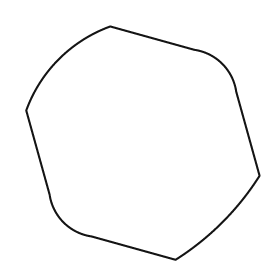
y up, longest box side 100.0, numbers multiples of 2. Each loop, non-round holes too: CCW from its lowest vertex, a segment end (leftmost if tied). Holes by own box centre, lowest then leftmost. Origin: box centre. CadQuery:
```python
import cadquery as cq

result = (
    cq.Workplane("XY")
    .moveTo(14.0, -50.0)
    .threePointArc((34.0, -34.0), (50.0, -14.0))
    .lineTo(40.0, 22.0)
    .threePointArc((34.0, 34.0), (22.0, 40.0))
    .lineTo(-14.0, 50.0)
    .threePointArc((-36.0, 36.0), (-50.0, 14.0))
    .lineTo(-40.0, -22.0)
    .threePointArc((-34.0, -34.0), (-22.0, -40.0))
    .close()
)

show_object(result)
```